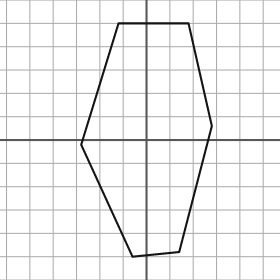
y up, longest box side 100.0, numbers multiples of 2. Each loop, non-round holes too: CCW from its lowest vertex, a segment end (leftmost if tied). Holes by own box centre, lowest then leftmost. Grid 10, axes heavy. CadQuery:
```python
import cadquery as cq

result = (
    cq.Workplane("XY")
    .moveTo(-6.0, -50.0)
    .lineTo(14.0, -48.0)
    .lineTo(28.0, 6.0)
    .lineTo(18.0, 50.0)
    .lineTo(-12.0, 50.0)
    .lineTo(-28.0, -2.0)
    .close()
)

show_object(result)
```